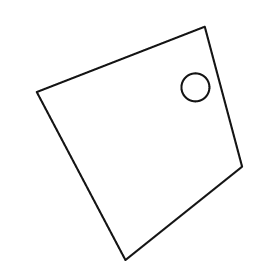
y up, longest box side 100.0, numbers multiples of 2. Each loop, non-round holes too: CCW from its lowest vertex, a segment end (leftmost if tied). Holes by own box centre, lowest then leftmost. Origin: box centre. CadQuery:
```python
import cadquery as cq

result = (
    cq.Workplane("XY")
    .moveTo(-6.0, -50.0)
    .lineTo(44.0, -10.0)
    .lineTo(28.0, 50.0)
    .lineTo(-44.0, 22.0)
    .close()
    .moveTo(24.0, 24.0)
    .circle(6.0)
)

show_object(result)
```